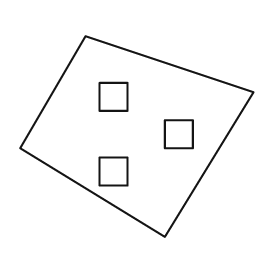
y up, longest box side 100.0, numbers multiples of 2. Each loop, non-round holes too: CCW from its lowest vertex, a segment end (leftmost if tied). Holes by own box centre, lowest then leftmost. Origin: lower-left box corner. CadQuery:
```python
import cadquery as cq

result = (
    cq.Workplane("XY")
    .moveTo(62.0, 0.0)
    .lineTo(100.0, 62.0)
    .lineTo(28.0, 86.0)
    .lineTo(0.0, 38.0)
    .close()
    .moveTo(34.0, 22.0)
    .lineTo(46.0, 22.0)
    .lineTo(46.0, 34.0)
    .lineTo(34.0, 34.0)
    .close()
    .moveTo(62.0, 38.0)
    .lineTo(74.0, 38.0)
    .lineTo(74.0, 50.0)
    .lineTo(62.0, 50.0)
    .close()
    .moveTo(34.0, 54.0)
    .lineTo(46.0, 54.0)
    .lineTo(46.0, 66.0)
    .lineTo(34.0, 66.0)
    .close()
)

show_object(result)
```